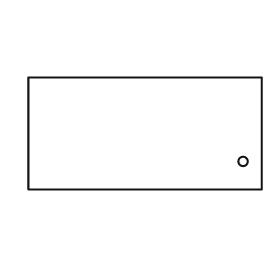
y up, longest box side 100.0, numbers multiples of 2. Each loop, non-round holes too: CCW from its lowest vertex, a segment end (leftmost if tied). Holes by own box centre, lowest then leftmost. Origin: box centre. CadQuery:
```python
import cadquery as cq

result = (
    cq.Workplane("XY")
    .moveTo(-50.0, -24.0)
    .lineTo(50.0, -24.0)
    .lineTo(50.0, 24.0)
    .lineTo(-50.0, 24.0)
    .close()
    .moveTo(42.0, -12.0)
    .circle(2.0)
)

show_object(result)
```